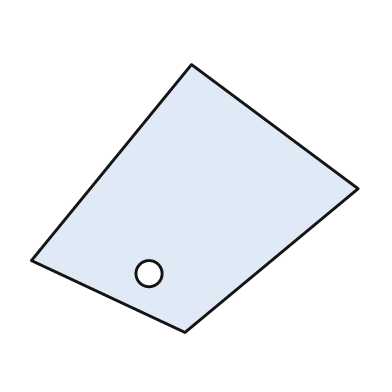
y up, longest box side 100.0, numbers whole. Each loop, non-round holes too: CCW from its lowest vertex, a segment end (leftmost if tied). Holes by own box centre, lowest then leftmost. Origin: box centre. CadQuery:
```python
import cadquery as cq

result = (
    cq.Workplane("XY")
    .moveTo(-3.0, -41.0)
    .lineTo(50.0, 3.0)
    .lineTo(-1.0, 41.0)
    .lineTo(-50.0, -19.0)
    .close()
    .moveTo(-14.0, -23.0)
    .circle(4.0)
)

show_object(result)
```